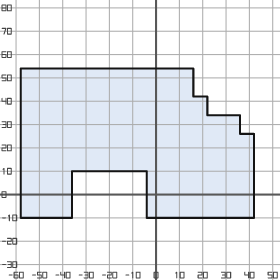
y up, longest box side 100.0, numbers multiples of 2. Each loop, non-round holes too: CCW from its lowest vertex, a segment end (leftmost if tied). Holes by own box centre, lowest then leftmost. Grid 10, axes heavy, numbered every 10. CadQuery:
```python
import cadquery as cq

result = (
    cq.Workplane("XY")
    .moveTo(-58.0, -10.0)
    .lineTo(-36.0, -10.0)
    .lineTo(-36.0, 10.0)
    .lineTo(-4.0, 10.0)
    .lineTo(-4.0, -10.0)
    .lineTo(42.0, -10.0)
    .lineTo(42.0, 26.0)
    .lineTo(36.0, 26.0)
    .lineTo(36.0, 34.0)
    .lineTo(22.0, 34.0)
    .lineTo(22.0, 42.0)
    .lineTo(16.0, 42.0)
    .lineTo(16.0, 54.0)
    .lineTo(-58.0, 54.0)
    .close()
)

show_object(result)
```